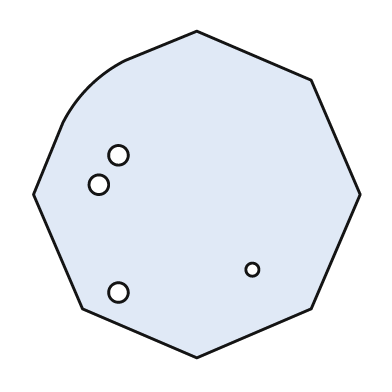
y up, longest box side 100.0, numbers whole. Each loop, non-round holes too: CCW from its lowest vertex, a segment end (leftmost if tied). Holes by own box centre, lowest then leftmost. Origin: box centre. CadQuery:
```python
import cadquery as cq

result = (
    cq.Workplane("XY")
    .moveTo(0.0, -50.0)
    .lineTo(35.0, -35.0)
    .lineTo(50.0, 0.0)
    .lineTo(35.0, 35.0)
    .lineTo(0.0, 50.0)
    .lineTo(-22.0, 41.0)
    .threePointArc((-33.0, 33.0), (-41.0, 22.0))
    .lineTo(-50.0, 0.0)
    .lineTo(-35.0, -35.0)
    .close()
    .moveTo(-24.0, -30.0)
    .circle(3.0)
    .moveTo(17.0, -23.0)
    .circle(2.0)
    .moveTo(-30.0, 3.0)
    .circle(3.0)
    .moveTo(-24.0, 12.0)
    .circle(3.0)
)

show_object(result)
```